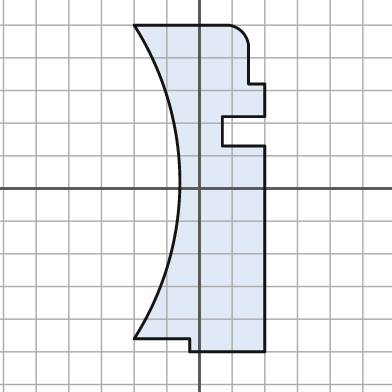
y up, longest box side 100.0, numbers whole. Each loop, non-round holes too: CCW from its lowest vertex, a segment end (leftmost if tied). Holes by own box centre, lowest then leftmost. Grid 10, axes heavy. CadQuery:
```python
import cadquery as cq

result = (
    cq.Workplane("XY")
    .moveTo(-3.0, -50.0)
    .lineTo(20.0, -50.0)
    .lineTo(20.0, 13.0)
    .lineTo(7.0, 13.0)
    .lineTo(7.0, 22.0)
    .lineTo(20.0, 22.0)
    .lineTo(20.0, 32.0)
    .lineTo(15.0, 32.0)
    .lineTo(15.0, 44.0)
    .threePointArc((13.0, 48.0), (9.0, 50.0))
    .lineTo(-20.0, 50.0)
    .threePointArc((-6.0, 2.0), (-20.0, -46.0))
    .lineTo(-3.0, -46.0)
    .close()
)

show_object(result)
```